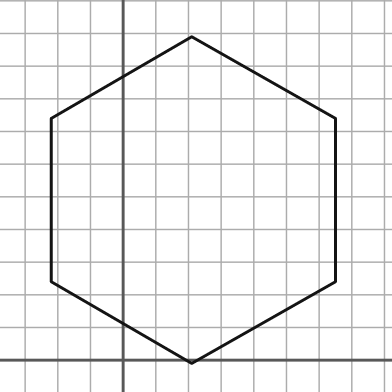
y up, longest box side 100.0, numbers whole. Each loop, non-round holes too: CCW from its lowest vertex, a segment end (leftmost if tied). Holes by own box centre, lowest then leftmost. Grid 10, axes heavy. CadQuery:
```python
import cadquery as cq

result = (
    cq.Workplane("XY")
    .moveTo(21.0, -1.0)
    .lineTo(65.0, 24.0)
    .lineTo(65.0, 74.0)
    .lineTo(21.0, 99.0)
    .lineTo(-22.0, 74.0)
    .lineTo(-22.0, 24.0)
    .close()
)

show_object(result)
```